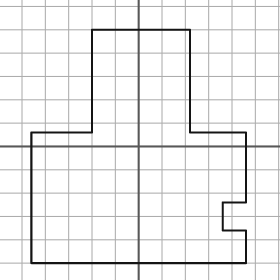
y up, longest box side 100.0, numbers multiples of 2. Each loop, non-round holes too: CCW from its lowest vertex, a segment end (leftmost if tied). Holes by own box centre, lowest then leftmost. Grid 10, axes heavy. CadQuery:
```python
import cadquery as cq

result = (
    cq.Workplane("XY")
    .moveTo(-46.0, -50.0)
    .lineTo(46.0, -50.0)
    .lineTo(46.0, -36.0)
    .lineTo(36.0, -36.0)
    .lineTo(36.0, -24.0)
    .lineTo(46.0, -24.0)
    .lineTo(46.0, 6.0)
    .lineTo(22.0, 6.0)
    .lineTo(22.0, 50.0)
    .lineTo(-20.0, 50.0)
    .lineTo(-20.0, 6.0)
    .lineTo(-46.0, 6.0)
    .close()
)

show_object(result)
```